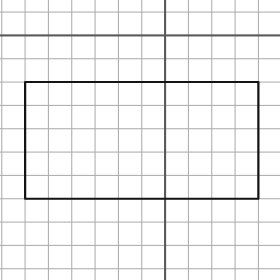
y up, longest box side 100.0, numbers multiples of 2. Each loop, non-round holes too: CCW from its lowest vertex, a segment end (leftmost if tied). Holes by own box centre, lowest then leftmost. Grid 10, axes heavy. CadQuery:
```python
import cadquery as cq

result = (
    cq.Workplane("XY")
    .moveTo(-60.0, -70.0)
    .lineTo(40.0, -70.0)
    .lineTo(40.0, -20.0)
    .lineTo(-60.0, -20.0)
    .close()
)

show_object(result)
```